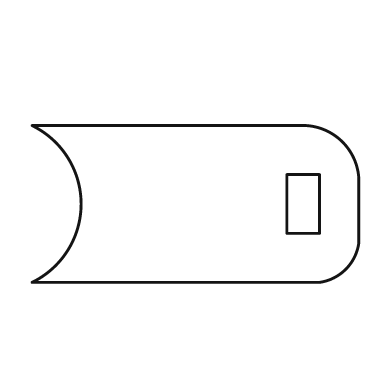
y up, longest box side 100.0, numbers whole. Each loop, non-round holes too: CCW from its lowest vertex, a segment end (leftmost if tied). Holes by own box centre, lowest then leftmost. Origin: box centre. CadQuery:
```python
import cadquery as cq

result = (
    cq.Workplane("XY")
    .moveTo(-50.0, -24.0)
    .lineTo(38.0, -24.0)
    .threePointArc((46.0, -20.0), (50.0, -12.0))
    .lineTo(50.0, 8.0)
    .threePointArc((45.0, 19.0), (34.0, 24.0))
    .lineTo(-50.0, 24.0)
    .threePointArc((-35.0, 0.0), (-50.0, -24.0))
    .close()
    .moveTo(28.0, -9.0)
    .lineTo(38.0, -9.0)
    .lineTo(38.0, 9.0)
    .lineTo(28.0, 9.0)
    .close()
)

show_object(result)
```